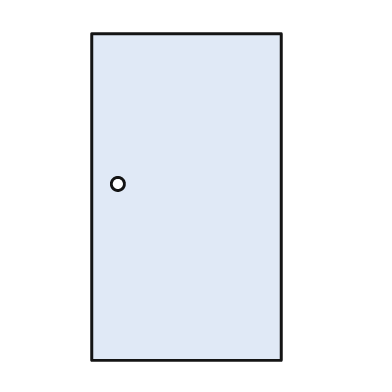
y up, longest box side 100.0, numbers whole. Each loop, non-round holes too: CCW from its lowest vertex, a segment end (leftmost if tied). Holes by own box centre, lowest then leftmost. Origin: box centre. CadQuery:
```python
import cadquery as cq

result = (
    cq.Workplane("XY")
    .moveTo(-29.0, -50.0)
    .lineTo(29.0, -50.0)
    .lineTo(29.0, 50.0)
    .lineTo(-29.0, 50.0)
    .close()
    .moveTo(-21.0, 4.0)
    .circle(2.0)
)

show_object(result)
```